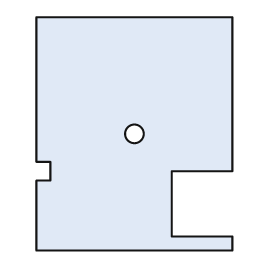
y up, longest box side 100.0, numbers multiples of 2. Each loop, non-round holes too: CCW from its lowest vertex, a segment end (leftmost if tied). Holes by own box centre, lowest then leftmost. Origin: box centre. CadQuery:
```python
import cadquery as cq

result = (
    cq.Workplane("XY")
    .moveTo(-42.0, -50.0)
    .lineTo(42.0, -50.0)
    .lineTo(42.0, -44.0)
    .lineTo(16.0, -44.0)
    .lineTo(16.0, -16.0)
    .lineTo(42.0, -16.0)
    .lineTo(42.0, 50.0)
    .lineTo(-42.0, 50.0)
    .lineTo(-42.0, -12.0)
    .lineTo(-36.0, -12.0)
    .lineTo(-36.0, -20.0)
    .lineTo(-42.0, -20.0)
    .close()
    .moveTo(0.0, 0.0)
    .circle(4.0)
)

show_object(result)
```